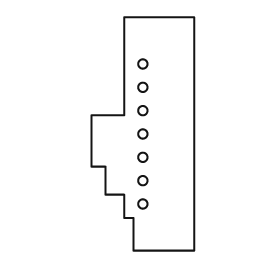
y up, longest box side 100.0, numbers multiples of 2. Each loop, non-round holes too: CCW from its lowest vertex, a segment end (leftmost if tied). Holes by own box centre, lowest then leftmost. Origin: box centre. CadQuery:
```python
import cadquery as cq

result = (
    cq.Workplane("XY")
    .moveTo(-4.0, -50.0)
    .lineTo(22.0, -50.0)
    .lineTo(22.0, 50.0)
    .lineTo(-8.0, 50.0)
    .lineTo(-8.0, 8.0)
    .lineTo(-22.0, 8.0)
    .lineTo(-22.0, -14.0)
    .lineTo(-16.0, -14.0)
    .lineTo(-16.0, -26.0)
    .lineTo(-8.0, -26.0)
    .lineTo(-8.0, -36.0)
    .lineTo(-4.0, -36.0)
    .close()
    .moveTo(0.0, -30.0)
    .circle(2.0)
    .moveTo(0.0, -20.0)
    .circle(2.0)
    .moveTo(0.0, -10.0)
    .circle(2.0)
    .moveTo(0.0, 0.0)
    .circle(2.0)
    .moveTo(0.0, 10.0)
    .circle(2.0)
    .moveTo(0.0, 20.0)
    .circle(2.0)
    .moveTo(0.0, 30.0)
    .circle(2.0)
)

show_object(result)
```